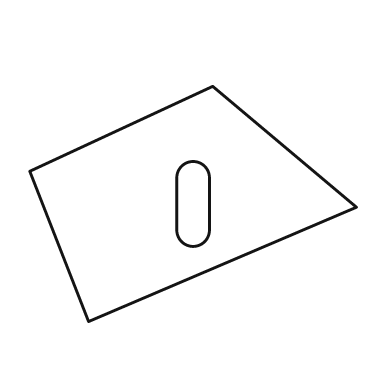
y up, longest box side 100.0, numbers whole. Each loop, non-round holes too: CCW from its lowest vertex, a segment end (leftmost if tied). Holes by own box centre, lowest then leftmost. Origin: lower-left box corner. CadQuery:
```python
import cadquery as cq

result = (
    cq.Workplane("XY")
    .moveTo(18.0, 0.0)
    .lineTo(100.0, 35.0)
    .lineTo(56.0, 72.0)
    .lineTo(0.0, 46.0)
    .close()
    .moveTo(45.0, 28.0)
    .threePointArc((50.0, 23.0), (55.0, 28.0))
    .lineTo(55.0, 44.0)
    .threePointArc((50.0, 49.0), (45.0, 44.0))
    .close()
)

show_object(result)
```